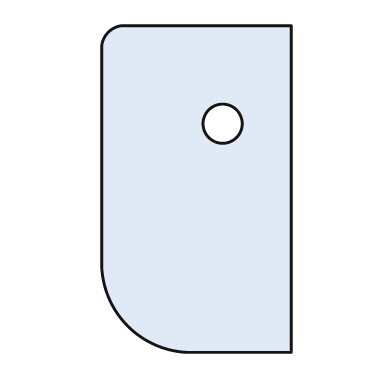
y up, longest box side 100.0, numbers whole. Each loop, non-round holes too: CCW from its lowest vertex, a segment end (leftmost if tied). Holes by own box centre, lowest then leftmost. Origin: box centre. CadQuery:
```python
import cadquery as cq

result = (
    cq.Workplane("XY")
    .moveTo(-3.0, -50.0)
    .lineTo(29.0, -50.0)
    .lineTo(29.0, 50.0)
    .lineTo(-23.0, 50.0)
    .threePointArc((-27.0, 48.0), (-29.0, 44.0))
    .lineTo(-29.0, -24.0)
    .threePointArc((-21.0, -42.0), (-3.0, -50.0))
    .close()
    .moveTo(8.0, 20.0)
    .circle(6.0)
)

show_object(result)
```